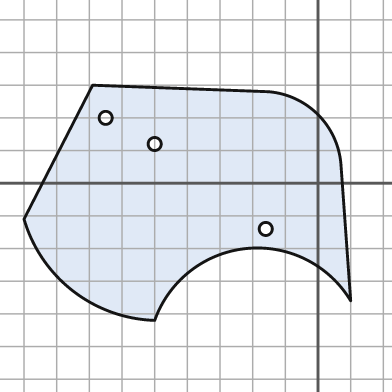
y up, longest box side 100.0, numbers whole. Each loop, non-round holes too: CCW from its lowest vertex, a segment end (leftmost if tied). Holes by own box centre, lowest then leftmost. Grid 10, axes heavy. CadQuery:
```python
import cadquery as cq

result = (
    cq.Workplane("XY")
    .moveTo(-50.0, -42.0)
    .threePointArc((-22.0, -20.0), (10.0, -36.0))
    .lineTo(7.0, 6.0)
    .threePointArc((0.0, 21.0), (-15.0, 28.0))
    .lineTo(-69.0, 30.0)
    .lineTo(-90.0, -11.0)
    .threePointArc((-75.0, -33.0), (-50.0, -42.0))
    .close()
    .moveTo(-16.0, -14.0)
    .circle(2.0)
    .moveTo(-50.0, 12.0)
    .circle(2.0)
    .moveTo(-65.0, 20.0)
    .circle(2.0)
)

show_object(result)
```